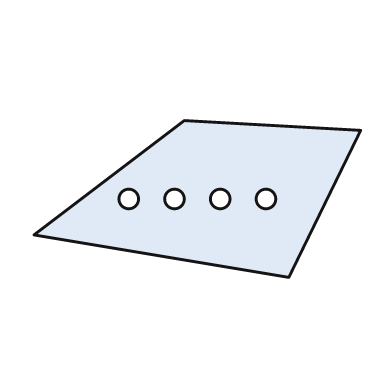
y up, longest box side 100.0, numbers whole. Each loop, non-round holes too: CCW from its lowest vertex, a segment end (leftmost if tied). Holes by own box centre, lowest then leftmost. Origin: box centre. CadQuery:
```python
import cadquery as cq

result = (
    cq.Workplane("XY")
    .moveTo(28.0, -24.0)
    .lineTo(50.0, 21.0)
    .lineTo(-4.0, 24.0)
    .lineTo(-50.0, -11.0)
    .close()
    .moveTo(-21.0, 0.0)
    .circle(3.0)
    .moveTo(-7.0, 0.0)
    .circle(3.0)
    .moveTo(7.0, 0.0)
    .circle(3.0)
    .moveTo(21.0, 0.0)
    .circle(3.0)
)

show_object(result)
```